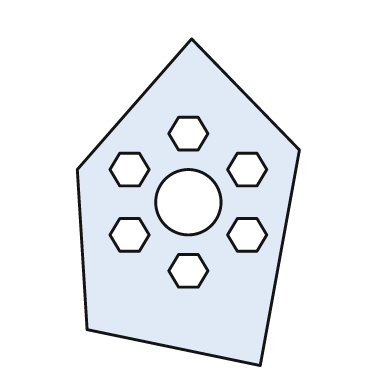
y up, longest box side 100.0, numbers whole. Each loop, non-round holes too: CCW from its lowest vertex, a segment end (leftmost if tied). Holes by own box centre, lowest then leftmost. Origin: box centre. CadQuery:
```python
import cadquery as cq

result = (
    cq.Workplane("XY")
    .moveTo(22.0, -50.0)
    .lineTo(34.0, 16.0)
    .lineTo(1.0, 50.0)
    .lineTo(-34.0, 10.0)
    .lineTo(-31.0, -39.0)
    .close()
    .moveTo(-3.0, -26.0)
    .lineTo(3.0, -26.0)
    .lineTo(6.0, -21.0)
    .lineTo(3.0, -16.0)
    .lineTo(-3.0, -16.0)
    .lineTo(-6.0, -21.0)
    .close()
    .moveTo(-21.0, -15.0)
    .lineTo(-15.0, -15.0)
    .lineTo(-12.0, -10.0)
    .lineTo(-15.0, -5.0)
    .lineTo(-21.0, -5.0)
    .lineTo(-24.0, -10.0)
    .close()
    .moveTo(15.0, -15.0)
    .lineTo(21.0, -15.0)
    .lineTo(24.0, -10.0)
    .lineTo(21.0, -5.0)
    .lineTo(15.0, -5.0)
    .lineTo(12.0, -10.0)
    .close()
    .moveTo(0.0, 0.0)
    .circle(10.0)
    .moveTo(-21.0, 5.0)
    .lineTo(-15.0, 5.0)
    .lineTo(-12.0, 10.0)
    .lineTo(-15.0, 15.0)
    .lineTo(-21.0, 15.0)
    .lineTo(-24.0, 10.0)
    .close()
    .moveTo(15.0, 5.0)
    .lineTo(21.0, 5.0)
    .lineTo(24.0, 10.0)
    .lineTo(21.0, 15.0)
    .lineTo(15.0, 15.0)
    .lineTo(12.0, 10.0)
    .close()
    .moveTo(-3.0, 16.0)
    .lineTo(3.0, 16.0)
    .lineTo(6.0, 21.0)
    .lineTo(3.0, 26.0)
    .lineTo(-3.0, 26.0)
    .lineTo(-6.0, 21.0)
    .close()
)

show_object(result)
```